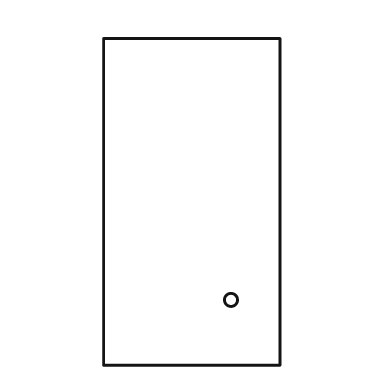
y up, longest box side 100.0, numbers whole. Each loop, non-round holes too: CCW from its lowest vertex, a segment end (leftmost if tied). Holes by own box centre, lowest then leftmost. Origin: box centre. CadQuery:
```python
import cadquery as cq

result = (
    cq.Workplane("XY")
    .moveTo(-27.0, -50.0)
    .lineTo(27.0, -50.0)
    .lineTo(27.0, 50.0)
    .lineTo(-27.0, 50.0)
    .close()
    .moveTo(12.0, -30.0)
    .circle(2.0)
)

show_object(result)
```